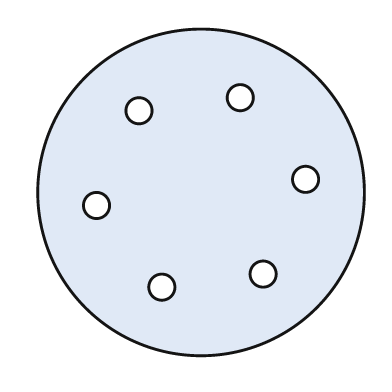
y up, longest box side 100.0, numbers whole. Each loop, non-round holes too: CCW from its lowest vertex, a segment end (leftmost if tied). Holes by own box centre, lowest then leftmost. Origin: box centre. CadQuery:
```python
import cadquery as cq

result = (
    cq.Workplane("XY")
    .moveTo(0.0, 0.0)
    .circle(50.0)
    .moveTo(-12.0, -29.0)
    .circle(4.0)
    .moveTo(19.0, -25.0)
    .circle(4.0)
    .moveTo(-32.0, -4.0)
    .circle(4.0)
    .moveTo(32.0, 4.0)
    .circle(4.0)
    .moveTo(-19.0, 25.0)
    .circle(4.0)
    .moveTo(12.0, 29.0)
    .circle(4.0)
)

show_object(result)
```